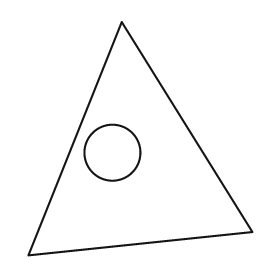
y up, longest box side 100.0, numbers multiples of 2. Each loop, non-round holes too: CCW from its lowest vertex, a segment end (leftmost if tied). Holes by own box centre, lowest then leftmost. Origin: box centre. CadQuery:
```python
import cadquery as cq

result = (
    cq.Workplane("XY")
    .moveTo(-48.0, -50.0)
    .lineTo(48.0, -40.0)
    .lineTo(-8.0, 50.0)
    .close()
    .moveTo(-12.0, -6.0)
    .circle(12.0)
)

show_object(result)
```